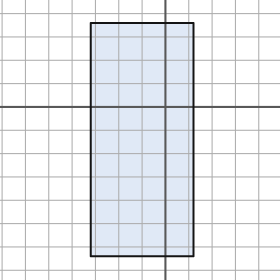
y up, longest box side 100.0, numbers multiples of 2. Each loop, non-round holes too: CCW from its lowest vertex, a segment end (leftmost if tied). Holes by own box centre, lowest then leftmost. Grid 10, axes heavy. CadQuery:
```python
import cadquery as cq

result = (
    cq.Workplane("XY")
    .moveTo(-32.0, -64.0)
    .lineTo(12.0, -64.0)
    .lineTo(12.0, 36.0)
    .lineTo(-32.0, 36.0)
    .close()
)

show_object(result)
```